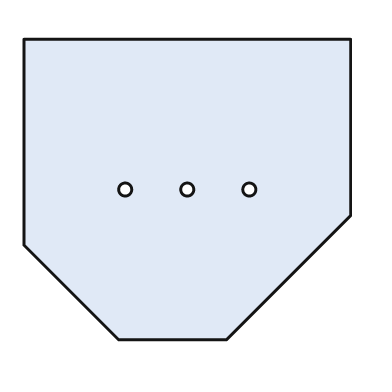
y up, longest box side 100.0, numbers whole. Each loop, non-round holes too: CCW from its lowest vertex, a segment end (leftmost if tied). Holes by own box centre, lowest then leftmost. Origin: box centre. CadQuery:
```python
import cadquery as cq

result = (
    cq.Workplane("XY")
    .moveTo(-21.0, -46.0)
    .lineTo(12.0, -46.0)
    .lineTo(50.0, -8.0)
    .lineTo(50.0, 46.0)
    .lineTo(-50.0, 46.0)
    .lineTo(-50.0, -17.0)
    .close()
    .moveTo(-19.0, 0.0)
    .circle(2.0)
    .moveTo(0.0, 0.0)
    .circle(2.0)
    .moveTo(19.0, 0.0)
    .circle(2.0)
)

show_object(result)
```